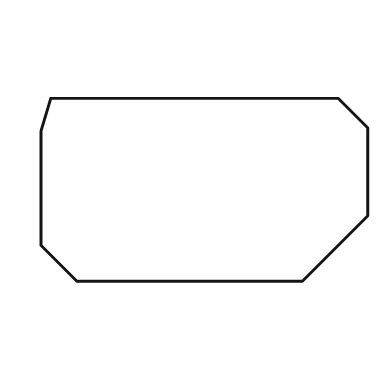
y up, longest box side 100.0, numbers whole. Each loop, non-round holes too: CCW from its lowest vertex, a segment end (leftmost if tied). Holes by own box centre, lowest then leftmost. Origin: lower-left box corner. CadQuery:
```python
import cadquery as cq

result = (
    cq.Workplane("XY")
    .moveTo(11.0, 0.0)
    .lineTo(80.0, 0.0)
    .lineTo(100.0, 20.0)
    .lineTo(100.0, 47.0)
    .lineTo(91.0, 56.0)
    .lineTo(3.0, 56.0)
    .lineTo(0.0, 46.0)
    .lineTo(0.0, 11.0)
    .close()
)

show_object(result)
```